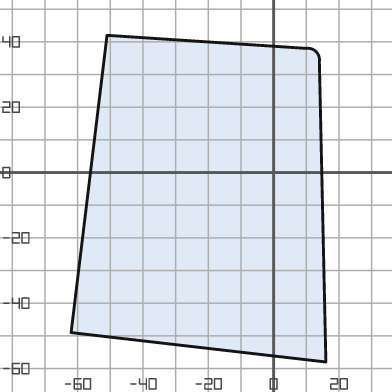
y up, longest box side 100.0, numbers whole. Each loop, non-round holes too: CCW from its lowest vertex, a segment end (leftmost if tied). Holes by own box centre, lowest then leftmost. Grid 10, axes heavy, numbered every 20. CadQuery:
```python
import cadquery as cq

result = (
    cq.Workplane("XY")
    .moveTo(16.0, -58.0)
    .lineTo(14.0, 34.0)
    .threePointArc((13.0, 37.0), (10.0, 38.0))
    .lineTo(-51.0, 42.0)
    .lineTo(-62.0, -49.0)
    .close()
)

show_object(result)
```